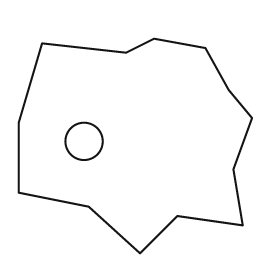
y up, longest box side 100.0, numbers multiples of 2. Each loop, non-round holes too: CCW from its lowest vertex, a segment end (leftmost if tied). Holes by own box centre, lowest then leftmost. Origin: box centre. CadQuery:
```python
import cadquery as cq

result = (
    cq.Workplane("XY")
    .moveTo(2.0, -46.0)
    .lineTo(18.0, -30.0)
    .lineTo(46.0, -34.0)
    .lineTo(42.0, -10.0)
    .lineTo(50.0, 12.0)
    .lineTo(40.0, 24.0)
    .lineTo(30.0, 42.0)
    .lineTo(8.0, 46.0)
    .lineTo(-4.0, 40.0)
    .lineTo(-40.0, 44.0)
    .lineTo(-50.0, 10.0)
    .lineTo(-50.0, -20.0)
    .lineTo(-20.0, -26.0)
    .close()
    .moveTo(-22.0, 2.0)
    .circle(8.0)
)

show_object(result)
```